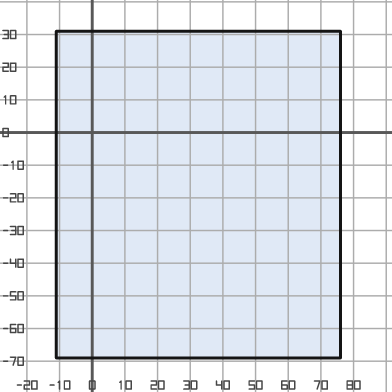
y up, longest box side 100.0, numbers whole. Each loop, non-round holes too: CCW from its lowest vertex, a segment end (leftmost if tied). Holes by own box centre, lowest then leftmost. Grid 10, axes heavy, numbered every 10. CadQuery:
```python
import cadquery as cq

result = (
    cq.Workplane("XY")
    .moveTo(-11.0, -69.0)
    .lineTo(76.0, -69.0)
    .lineTo(76.0, 31.0)
    .lineTo(-11.0, 31.0)
    .close()
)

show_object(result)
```